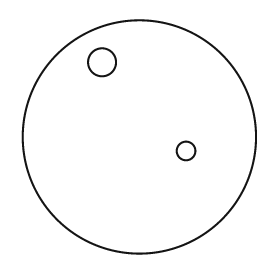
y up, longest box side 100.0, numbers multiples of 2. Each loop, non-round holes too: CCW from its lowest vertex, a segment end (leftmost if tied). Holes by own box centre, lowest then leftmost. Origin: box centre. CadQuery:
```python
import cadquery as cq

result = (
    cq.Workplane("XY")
    .moveTo(0.0, 0.0)
    .circle(50.0)
    .moveTo(20.0, -6.0)
    .circle(4.0)
    .moveTo(-16.0, 32.0)
    .circle(6.0)
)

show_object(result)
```